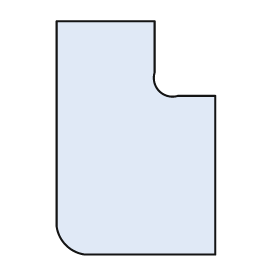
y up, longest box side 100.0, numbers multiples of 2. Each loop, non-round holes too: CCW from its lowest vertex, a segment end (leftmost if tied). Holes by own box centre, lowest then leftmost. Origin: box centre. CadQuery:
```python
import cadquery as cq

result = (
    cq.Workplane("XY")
    .moveTo(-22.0, -50.0)
    .lineTo(34.0, -50.0)
    .lineTo(34.0, 18.0)
    .lineTo(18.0, 18.0)
    .threePointArc((10.0, 20.0), (8.0, 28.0))
    .lineTo(8.0, 50.0)
    .lineTo(-34.0, 50.0)
    .lineTo(-34.0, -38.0)
    .threePointArc((-30.0, -46.0), (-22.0, -50.0))
    .close()
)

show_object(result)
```